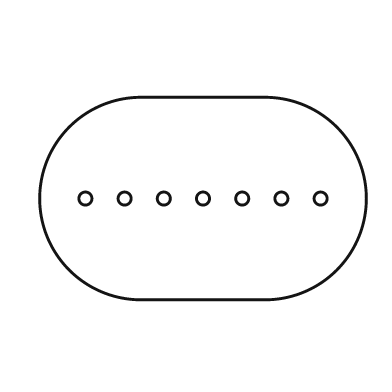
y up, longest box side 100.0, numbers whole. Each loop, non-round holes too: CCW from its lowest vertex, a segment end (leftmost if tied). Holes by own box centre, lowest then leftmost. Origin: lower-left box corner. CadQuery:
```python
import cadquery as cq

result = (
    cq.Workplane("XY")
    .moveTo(31.0, 0.0)
    .lineTo(69.0, 0.0)
    .threePointArc((100.0, 31.0), (69.0, 62.0))
    .lineTo(31.0, 62.0)
    .threePointArc((0.0, 31.0), (31.0, 0.0))
    .close()
    .moveTo(14.0, 31.0)
    .circle(2.0)
    .moveTo(26.0, 31.0)
    .circle(2.0)
    .moveTo(38.0, 31.0)
    .circle(2.0)
    .moveTo(50.0, 31.0)
    .circle(2.0)
    .moveTo(62.0, 31.0)
    .circle(2.0)
    .moveTo(74.0, 31.0)
    .circle(2.0)
    .moveTo(86.0, 31.0)
    .circle(2.0)
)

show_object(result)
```